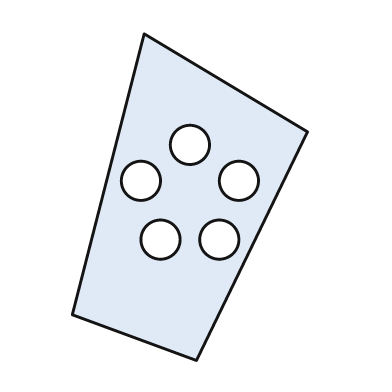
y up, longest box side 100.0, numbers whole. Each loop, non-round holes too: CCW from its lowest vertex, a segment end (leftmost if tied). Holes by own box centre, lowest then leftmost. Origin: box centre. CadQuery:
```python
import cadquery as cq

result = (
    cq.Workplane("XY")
    .moveTo(2.0, -50.0)
    .lineTo(36.0, 20.0)
    .lineTo(-14.0, 50.0)
    .lineTo(-36.0, -36.0)
    .close()
    .moveTo(-9.0, -13.0)
    .circle(6.0)
    .moveTo(9.0, -13.0)
    .circle(6.0)
    .moveTo(-15.0, 5.0)
    .circle(6.0)
    .moveTo(15.0, 5.0)
    .circle(6.0)
    .moveTo(0.0, 16.0)
    .circle(6.0)
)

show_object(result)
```